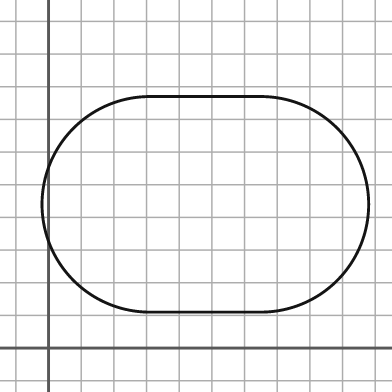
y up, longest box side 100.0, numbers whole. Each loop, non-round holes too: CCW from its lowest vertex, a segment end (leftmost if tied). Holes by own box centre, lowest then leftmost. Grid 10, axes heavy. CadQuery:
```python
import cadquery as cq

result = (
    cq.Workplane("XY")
    .moveTo(31.0, 11.0)
    .lineTo(65.0, 11.0)
    .threePointArc((98.0, 44.0), (65.0, 77.0))
    .lineTo(31.0, 77.0)
    .threePointArc((-2.0, 44.0), (31.0, 11.0))
    .close()
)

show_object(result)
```